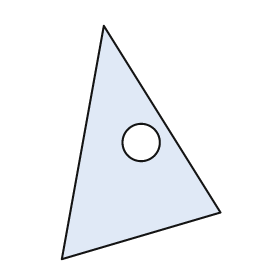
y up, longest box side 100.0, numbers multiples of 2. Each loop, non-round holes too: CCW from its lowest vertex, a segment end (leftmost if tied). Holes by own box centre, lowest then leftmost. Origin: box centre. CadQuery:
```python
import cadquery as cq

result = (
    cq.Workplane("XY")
    .moveTo(-34.0, -50.0)
    .lineTo(34.0, -30.0)
    .lineTo(-16.0, 50.0)
    .close()
    .moveTo(0.0, 0.0)
    .circle(8.0)
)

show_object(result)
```